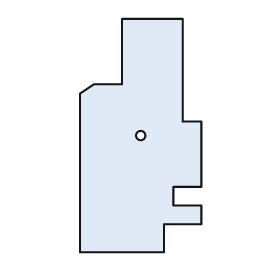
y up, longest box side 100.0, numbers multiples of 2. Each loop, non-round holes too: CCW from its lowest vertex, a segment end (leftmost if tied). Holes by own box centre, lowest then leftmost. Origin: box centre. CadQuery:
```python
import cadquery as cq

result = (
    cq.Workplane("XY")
    .moveTo(-26.0, -50.0)
    .lineTo(10.0, -50.0)
    .lineTo(10.0, -38.0)
    .lineTo(26.0, -38.0)
    .lineTo(26.0, -30.0)
    .lineTo(14.0, -30.0)
    .lineTo(14.0, -22.0)
    .lineTo(26.0, -22.0)
    .lineTo(26.0, 6.0)
    .lineTo(18.0, 6.0)
    .lineTo(18.0, 50.0)
    .lineTo(-8.0, 50.0)
    .lineTo(-8.0, 22.0)
    .lineTo(-20.0, 22.0)
    .lineTo(-26.0, 18.0)
    .close()
    .moveTo(0.0, 0.0)
    .circle(2.0)
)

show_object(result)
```